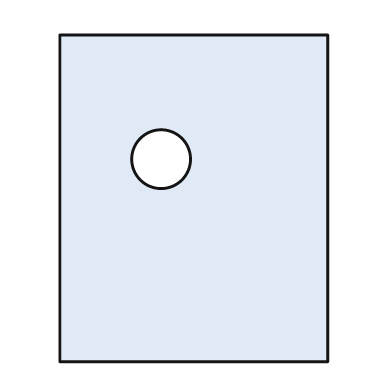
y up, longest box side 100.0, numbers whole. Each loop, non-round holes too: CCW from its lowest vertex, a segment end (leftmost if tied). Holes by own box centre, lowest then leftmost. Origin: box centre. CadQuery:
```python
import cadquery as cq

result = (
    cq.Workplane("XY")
    .moveTo(-41.0, -50.0)
    .lineTo(41.0, -50.0)
    .lineTo(41.0, 50.0)
    .lineTo(-41.0, 50.0)
    .close()
    .moveTo(-10.0, 12.0)
    .circle(9.0)
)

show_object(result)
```